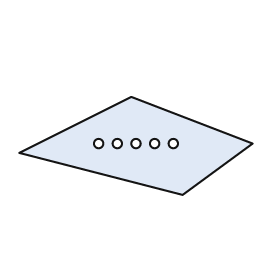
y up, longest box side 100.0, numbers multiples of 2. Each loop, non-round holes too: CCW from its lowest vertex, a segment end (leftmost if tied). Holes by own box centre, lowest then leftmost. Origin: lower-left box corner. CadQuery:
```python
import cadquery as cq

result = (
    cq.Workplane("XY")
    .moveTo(70.0, 0.0)
    .lineTo(100.0, 22.0)
    .lineTo(48.0, 42.0)
    .lineTo(0.0, 18.0)
    .close()
    .moveTo(34.0, 22.0)
    .circle(2.0)
    .moveTo(42.0, 22.0)
    .circle(2.0)
    .moveTo(50.0, 22.0)
    .circle(2.0)
    .moveTo(58.0, 22.0)
    .circle(2.0)
    .moveTo(66.0, 22.0)
    .circle(2.0)
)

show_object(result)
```